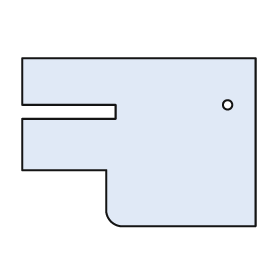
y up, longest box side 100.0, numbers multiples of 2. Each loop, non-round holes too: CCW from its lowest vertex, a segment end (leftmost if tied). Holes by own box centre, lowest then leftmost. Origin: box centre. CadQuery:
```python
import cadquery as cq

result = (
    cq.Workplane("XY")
    .moveTo(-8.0, -36.0)
    .lineTo(50.0, -36.0)
    .lineTo(50.0, 36.0)
    .lineTo(-50.0, 36.0)
    .lineTo(-50.0, 16.0)
    .lineTo(-10.0, 16.0)
    .lineTo(-10.0, 10.0)
    .lineTo(-50.0, 10.0)
    .lineTo(-50.0, -12.0)
    .lineTo(-14.0, -12.0)
    .lineTo(-14.0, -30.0)
    .threePointArc((-12.0, -34.0), (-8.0, -36.0))
    .close()
    .moveTo(38.0, 16.0)
    .circle(2.0)
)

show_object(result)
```